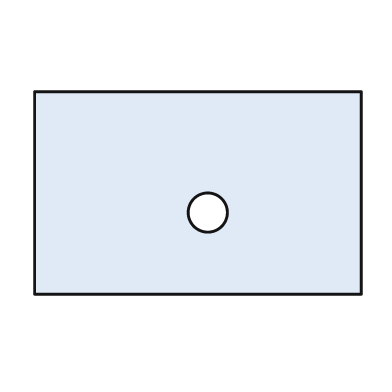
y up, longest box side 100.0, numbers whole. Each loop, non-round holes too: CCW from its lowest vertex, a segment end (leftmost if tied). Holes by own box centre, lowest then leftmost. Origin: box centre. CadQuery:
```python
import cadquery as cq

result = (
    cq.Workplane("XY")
    .moveTo(-50.0, -31.0)
    .lineTo(50.0, -31.0)
    .lineTo(50.0, 31.0)
    .lineTo(-50.0, 31.0)
    .close()
    .moveTo(3.0, -6.0)
    .circle(6.0)
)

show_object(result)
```